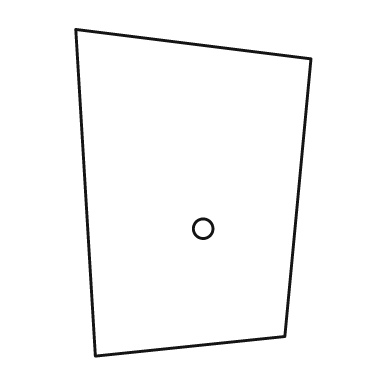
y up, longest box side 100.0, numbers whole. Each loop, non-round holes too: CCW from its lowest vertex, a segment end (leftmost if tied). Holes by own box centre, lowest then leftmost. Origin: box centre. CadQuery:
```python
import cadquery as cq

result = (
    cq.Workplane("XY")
    .moveTo(-30.0, -50.0)
    .lineTo(28.0, -44.0)
    .lineTo(36.0, 41.0)
    .lineTo(-36.0, 50.0)
    .close()
    .moveTo(3.0, -11.0)
    .circle(3.0)
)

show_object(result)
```